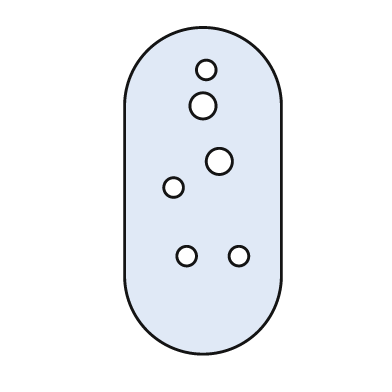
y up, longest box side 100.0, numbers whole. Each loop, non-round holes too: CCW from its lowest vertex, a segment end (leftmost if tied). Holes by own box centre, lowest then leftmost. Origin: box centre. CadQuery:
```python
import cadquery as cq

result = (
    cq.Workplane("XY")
    .moveTo(-24.0, -26.0)
    .threePointArc((0.0, -50.0), (24.0, -26.0))
    .lineTo(24.0, 26.0)
    .threePointArc((0.0, 50.0), (-24.0, 26.0))
    .close()
    .moveTo(-5.0, -20.0)
    .circle(3.0)
    .moveTo(11.0, -20.0)
    .circle(3.0)
    .moveTo(-9.0, 1.0)
    .circle(3.0)
    .moveTo(5.0, 9.0)
    .circle(4.0)
    .moveTo(0.0, 26.0)
    .circle(4.0)
    .moveTo(1.0, 37.0)
    .circle(3.0)
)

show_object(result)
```